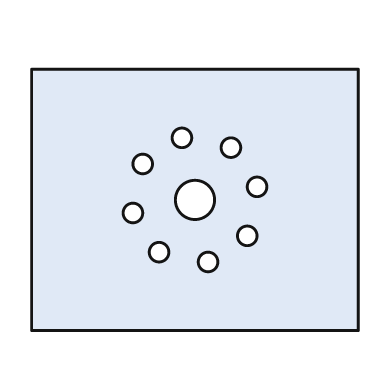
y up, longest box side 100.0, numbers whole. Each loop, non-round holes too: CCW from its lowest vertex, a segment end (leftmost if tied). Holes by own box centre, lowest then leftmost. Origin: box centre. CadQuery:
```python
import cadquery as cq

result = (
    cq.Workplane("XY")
    .moveTo(-50.0, -40.0)
    .lineTo(50.0, -40.0)
    .lineTo(50.0, 40.0)
    .lineTo(-50.0, 40.0)
    .close()
    .moveTo(4.0, -19.0)
    .circle(3.0)
    .moveTo(-11.0, -16.0)
    .circle(3.0)
    .moveTo(16.0, -11.0)
    .circle(3.0)
    .moveTo(-19.0, -4.0)
    .circle(3.0)
    .moveTo(0.0, 0.0)
    .circle(6.0)
    .moveTo(19.0, 4.0)
    .circle(3.0)
    .moveTo(-16.0, 11.0)
    .circle(3.0)
    .moveTo(11.0, 16.0)
    .circle(3.0)
    .moveTo(-4.0, 19.0)
    .circle(3.0)
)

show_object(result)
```